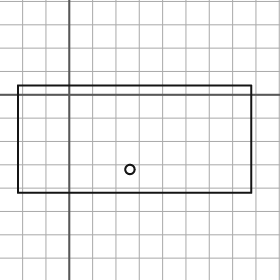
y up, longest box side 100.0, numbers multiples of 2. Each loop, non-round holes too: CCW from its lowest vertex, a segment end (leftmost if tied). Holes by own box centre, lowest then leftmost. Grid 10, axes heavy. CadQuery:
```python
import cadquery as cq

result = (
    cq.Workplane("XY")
    .moveTo(-22.0, -42.0)
    .lineTo(78.0, -42.0)
    .lineTo(78.0, 4.0)
    .lineTo(-22.0, 4.0)
    .close()
    .moveTo(26.0, -32.0)
    .circle(2.0)
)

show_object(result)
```